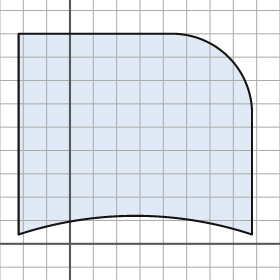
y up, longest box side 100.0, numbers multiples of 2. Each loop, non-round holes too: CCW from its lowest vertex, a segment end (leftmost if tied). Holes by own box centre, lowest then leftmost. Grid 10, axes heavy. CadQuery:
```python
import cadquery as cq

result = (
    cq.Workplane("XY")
    .moveTo(-22.0, 4.0)
    .threePointArc((28.0, 12.0), (78.0, 4.0))
    .lineTo(78.0, 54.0)
    .threePointArc((68.0, 80.0), (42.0, 90.0))
    .lineTo(-22.0, 90.0)
    .close()
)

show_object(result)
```